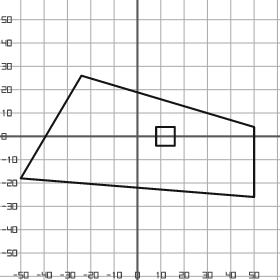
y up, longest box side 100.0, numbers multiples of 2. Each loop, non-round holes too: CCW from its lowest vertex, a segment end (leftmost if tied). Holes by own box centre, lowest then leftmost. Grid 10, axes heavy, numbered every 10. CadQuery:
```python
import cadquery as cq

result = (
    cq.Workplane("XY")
    .moveTo(50.0, -26.0)
    .lineTo(50.0, 4.0)
    .lineTo(-24.0, 26.0)
    .lineTo(-50.0, -18.0)
    .close()
    .moveTo(8.0, -4.0)
    .lineTo(16.0, -4.0)
    .lineTo(16.0, 4.0)
    .lineTo(8.0, 4.0)
    .close()
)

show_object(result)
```